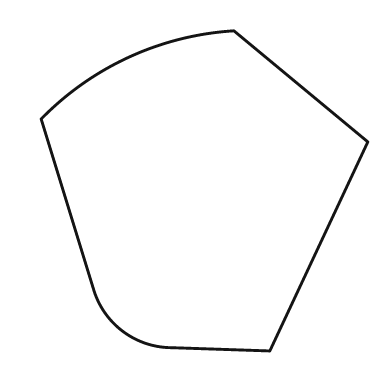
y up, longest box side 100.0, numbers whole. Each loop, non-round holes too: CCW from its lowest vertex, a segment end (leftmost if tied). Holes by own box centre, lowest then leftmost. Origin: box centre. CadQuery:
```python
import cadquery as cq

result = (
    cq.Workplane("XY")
    .moveTo(20.0, -49.0)
    .lineTo(50.0, 15.0)
    .lineTo(9.0, 49.0)
    .threePointArc((-23.0, 41.0), (-50.0, 22.0))
    .lineTo(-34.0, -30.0)
    .threePointArc((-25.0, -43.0), (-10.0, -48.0))
    .close()
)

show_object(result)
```